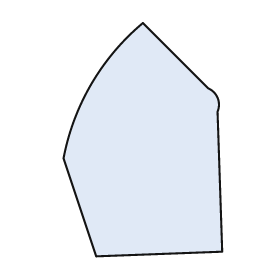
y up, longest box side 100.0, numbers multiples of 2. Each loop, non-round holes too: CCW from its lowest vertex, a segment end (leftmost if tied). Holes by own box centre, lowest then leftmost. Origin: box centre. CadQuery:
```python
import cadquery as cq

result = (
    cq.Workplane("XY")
    .moveTo(-20.0, -50.0)
    .lineTo(34.0, -48.0)
    .lineTo(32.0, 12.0)
    .threePointArc((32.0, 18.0), (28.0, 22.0))
    .lineTo(0.0, 50.0)
    .threePointArc((-22.0, 24.0), (-34.0, -8.0))
    .close()
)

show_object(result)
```